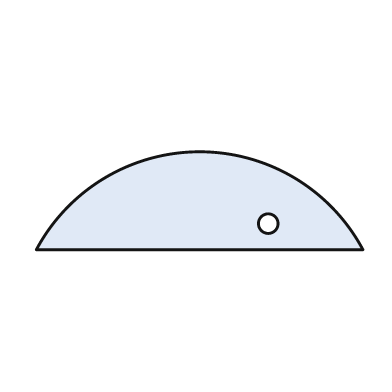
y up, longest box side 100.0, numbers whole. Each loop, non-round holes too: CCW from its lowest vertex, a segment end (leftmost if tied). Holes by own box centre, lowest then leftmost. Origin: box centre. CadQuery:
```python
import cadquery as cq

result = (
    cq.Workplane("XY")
    .moveTo(-50.0, -15.0)
    .lineTo(50.0, -15.0)
    .threePointArc((0.0, 15.0), (-50.0, -15.0))
    .close()
    .moveTo(21.0, -7.0)
    .circle(3.0)
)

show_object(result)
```